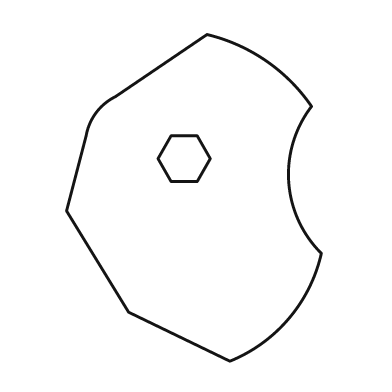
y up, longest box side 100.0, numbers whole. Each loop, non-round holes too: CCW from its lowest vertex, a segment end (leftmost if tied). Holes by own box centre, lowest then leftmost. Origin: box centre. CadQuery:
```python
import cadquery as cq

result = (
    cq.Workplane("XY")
    .moveTo(11.0, -50.0)
    .threePointArc((29.0, -37.0), (39.0, -17.0))
    .threePointArc((29.0, 5.0), (36.0, 28.0))
    .threePointArc((22.0, 42.0), (4.0, 50.0))
    .lineTo(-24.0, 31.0)
    .threePointArc((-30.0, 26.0), (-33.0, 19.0))
    .lineTo(-39.0, -4.0)
    .lineTo(-20.0, -35.0)
    .close()
    .moveTo(-7.0, 5.0)
    .lineTo(1.0, 5.0)
    .lineTo(5.0, 12.0)
    .lineTo(1.0, 19.0)
    .lineTo(-7.0, 19.0)
    .lineTo(-11.0, 12.0)
    .close()
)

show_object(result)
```